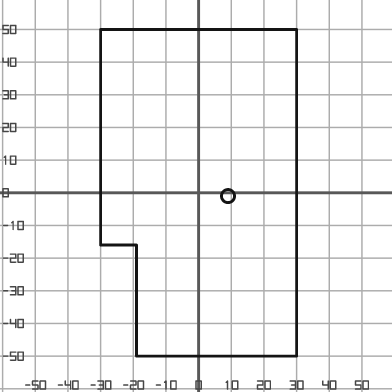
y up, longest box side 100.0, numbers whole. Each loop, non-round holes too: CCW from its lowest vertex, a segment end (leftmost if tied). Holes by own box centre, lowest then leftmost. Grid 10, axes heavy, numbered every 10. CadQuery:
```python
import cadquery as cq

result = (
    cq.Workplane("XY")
    .moveTo(-19.0, -50.0)
    .lineTo(30.0, -50.0)
    .lineTo(30.0, 50.0)
    .lineTo(-30.0, 50.0)
    .lineTo(-30.0, -16.0)
    .lineTo(-19.0, -16.0)
    .close()
    .moveTo(9.0, -1.0)
    .circle(2.0)
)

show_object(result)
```